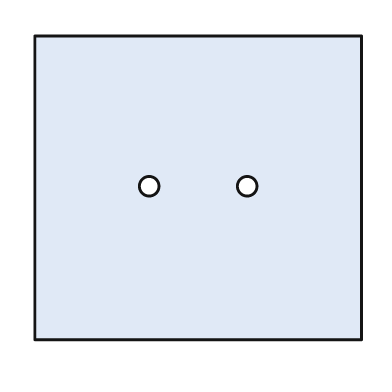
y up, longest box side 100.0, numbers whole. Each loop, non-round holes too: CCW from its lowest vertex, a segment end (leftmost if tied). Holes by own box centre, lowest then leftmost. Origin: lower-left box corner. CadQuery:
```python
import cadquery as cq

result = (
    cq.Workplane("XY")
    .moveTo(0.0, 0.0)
    .lineTo(100.0, 0.0)
    .lineTo(100.0, 93.0)
    .lineTo(0.0, 93.0)
    .close()
    .moveTo(35.0, 47.0)
    .circle(3.0)
    .moveTo(65.0, 47.0)
    .circle(3.0)
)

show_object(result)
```